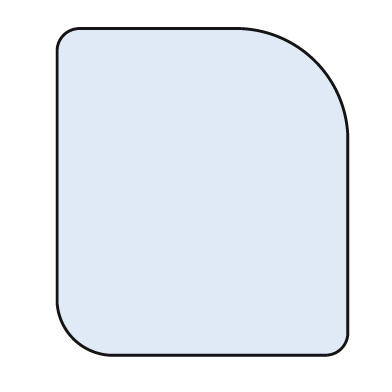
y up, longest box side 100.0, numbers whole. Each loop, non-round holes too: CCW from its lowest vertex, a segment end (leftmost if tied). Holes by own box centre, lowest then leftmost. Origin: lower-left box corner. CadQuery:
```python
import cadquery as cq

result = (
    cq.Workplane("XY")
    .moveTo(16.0, 0.0)
    .lineTo(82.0, 0.0)
    .threePointArc((87.0, 2.0), (89.0, 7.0))
    .lineTo(89.0, 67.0)
    .threePointArc((79.0, 90.0), (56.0, 100.0))
    .lineTo(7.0, 100.0)
    .threePointArc((2.0, 98.0), (0.0, 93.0))
    .lineTo(0.0, 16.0)
    .threePointArc((5.0, 5.0), (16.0, 0.0))
    .close()
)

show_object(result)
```